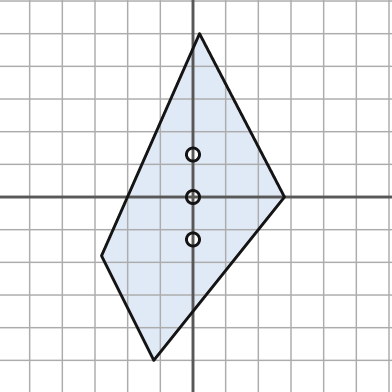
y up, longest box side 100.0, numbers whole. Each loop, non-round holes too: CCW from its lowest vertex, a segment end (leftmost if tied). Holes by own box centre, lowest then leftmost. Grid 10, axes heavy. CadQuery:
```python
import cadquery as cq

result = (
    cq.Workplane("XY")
    .moveTo(-12.0, -50.0)
    .lineTo(28.0, 0.0)
    .lineTo(2.0, 50.0)
    .lineTo(-28.0, -18.0)
    .close()
    .moveTo(0.0, -13.0)
    .circle(2.0)
    .moveTo(0.0, 0.0)
    .circle(2.0)
    .moveTo(0.0, 13.0)
    .circle(2.0)
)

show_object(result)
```